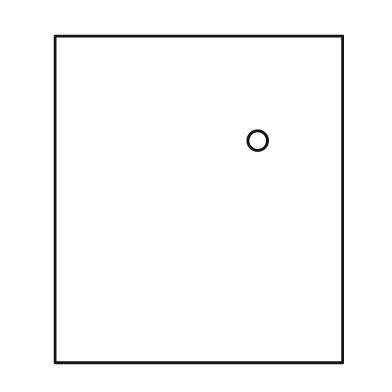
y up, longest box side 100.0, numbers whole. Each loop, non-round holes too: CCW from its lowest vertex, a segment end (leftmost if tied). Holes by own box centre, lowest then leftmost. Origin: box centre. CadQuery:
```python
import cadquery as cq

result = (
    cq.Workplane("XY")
    .moveTo(-44.0, -50.0)
    .lineTo(44.0, -50.0)
    .lineTo(44.0, 50.0)
    .lineTo(-44.0, 50.0)
    .close()
    .moveTo(18.0, 18.0)
    .circle(3.0)
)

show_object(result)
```